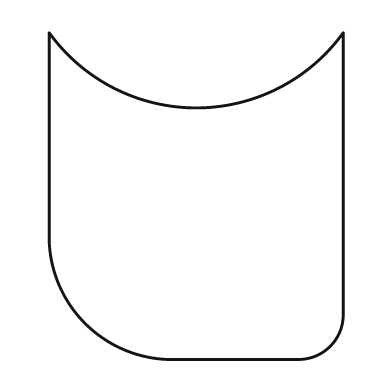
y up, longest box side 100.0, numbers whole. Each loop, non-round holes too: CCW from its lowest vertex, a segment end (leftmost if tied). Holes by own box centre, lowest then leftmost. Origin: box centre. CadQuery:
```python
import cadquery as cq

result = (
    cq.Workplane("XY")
    .moveTo(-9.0, -50.0)
    .lineTo(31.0, -50.0)
    .threePointArc((41.0, -46.0), (45.0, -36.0))
    .lineTo(45.0, 50.0)
    .threePointArc((0.0, 27.0), (-45.0, 50.0))
    .lineTo(-45.0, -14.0)
    .threePointArc((-34.0, -39.0), (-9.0, -50.0))
    .close()
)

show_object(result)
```